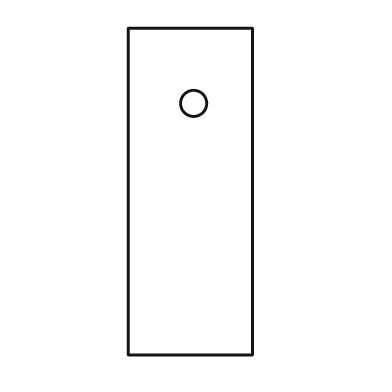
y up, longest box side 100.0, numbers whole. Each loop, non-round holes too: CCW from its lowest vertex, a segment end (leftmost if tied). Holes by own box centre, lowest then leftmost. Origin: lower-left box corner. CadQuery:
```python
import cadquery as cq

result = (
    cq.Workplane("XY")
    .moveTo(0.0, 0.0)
    .lineTo(38.0, 0.0)
    .lineTo(38.0, 100.0)
    .lineTo(0.0, 100.0)
    .close()
    .moveTo(20.0, 77.0)
    .circle(4.0)
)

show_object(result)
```